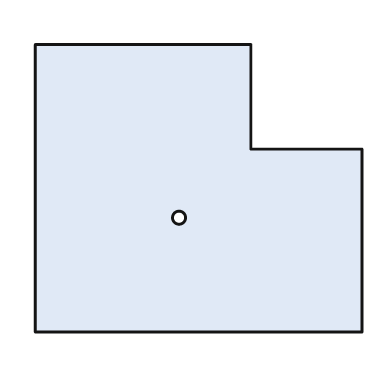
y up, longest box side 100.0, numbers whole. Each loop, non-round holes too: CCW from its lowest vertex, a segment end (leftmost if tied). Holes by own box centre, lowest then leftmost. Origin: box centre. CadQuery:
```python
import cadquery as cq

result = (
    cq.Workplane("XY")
    .moveTo(-50.0, -44.0)
    .lineTo(50.0, -44.0)
    .lineTo(50.0, 12.0)
    .lineTo(16.0, 12.0)
    .lineTo(16.0, 44.0)
    .lineTo(-50.0, 44.0)
    .close()
    .moveTo(-6.0, -9.0)
    .circle(2.0)
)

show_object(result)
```